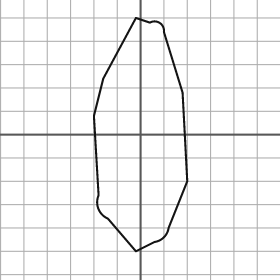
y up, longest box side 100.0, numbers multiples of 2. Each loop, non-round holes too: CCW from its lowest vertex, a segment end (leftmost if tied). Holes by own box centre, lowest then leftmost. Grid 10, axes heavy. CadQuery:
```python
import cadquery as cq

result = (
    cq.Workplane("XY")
    .moveTo(-2.0, -50.0)
    .lineTo(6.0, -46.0)
    .threePointArc((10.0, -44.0), (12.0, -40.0))
    .lineTo(20.0, -20.0)
    .lineTo(18.0, 18.0)
    .lineTo(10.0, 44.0)
    .threePointArc((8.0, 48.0), (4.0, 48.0))
    .lineTo(-2.0, 50.0)
    .lineTo(-16.0, 24.0)
    .lineTo(-20.0, 8.0)
    .lineTo(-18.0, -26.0)
    .threePointArc((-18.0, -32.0), (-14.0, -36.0))
    .close()
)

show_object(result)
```